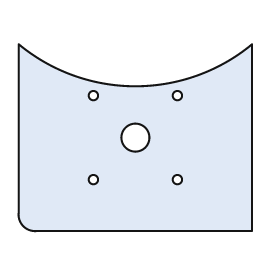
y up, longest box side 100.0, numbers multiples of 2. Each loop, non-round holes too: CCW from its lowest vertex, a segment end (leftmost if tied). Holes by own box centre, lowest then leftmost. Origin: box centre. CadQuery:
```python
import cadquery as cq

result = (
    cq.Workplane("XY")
    .moveTo(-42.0, -40.0)
    .lineTo(50.0, -40.0)
    .lineTo(50.0, 40.0)
    .threePointArc((0.0, 22.0), (-50.0, 40.0))
    .lineTo(-50.0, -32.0)
    .threePointArc((-48.0, -38.0), (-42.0, -40.0))
    .close()
    .moveTo(-18.0, -18.0)
    .circle(2.0)
    .moveTo(18.0, -18.0)
    .circle(2.0)
    .moveTo(0.0, 0.0)
    .circle(6.0)
    .moveTo(-18.0, 18.0)
    .circle(2.0)
    .moveTo(18.0, 18.0)
    .circle(2.0)
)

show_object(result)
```